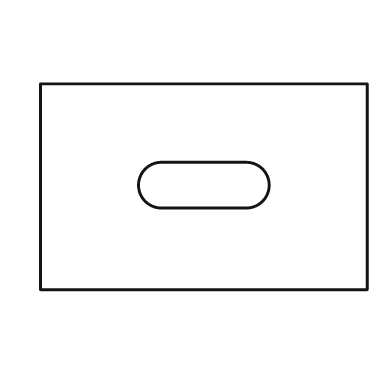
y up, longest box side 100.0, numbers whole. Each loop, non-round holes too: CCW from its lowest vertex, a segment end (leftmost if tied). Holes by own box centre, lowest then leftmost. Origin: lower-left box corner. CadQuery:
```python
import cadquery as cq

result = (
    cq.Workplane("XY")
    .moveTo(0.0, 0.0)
    .lineTo(100.0, 0.0)
    .lineTo(100.0, 63.0)
    .lineTo(0.0, 63.0)
    .close()
    .moveTo(37.0, 25.0)
    .lineTo(63.0, 25.0)
    .threePointArc((70.0, 32.0), (63.0, 39.0))
    .lineTo(37.0, 39.0)
    .threePointArc((30.0, 32.0), (37.0, 25.0))
    .close()
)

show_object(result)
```